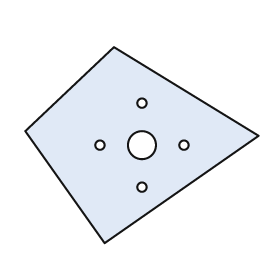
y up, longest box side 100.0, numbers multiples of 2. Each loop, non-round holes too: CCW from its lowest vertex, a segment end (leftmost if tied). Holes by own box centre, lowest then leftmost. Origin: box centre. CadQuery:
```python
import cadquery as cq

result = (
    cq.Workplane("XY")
    .moveTo(-16.0, -42.0)
    .lineTo(50.0, 4.0)
    .lineTo(-12.0, 42.0)
    .lineTo(-50.0, 6.0)
    .close()
    .moveTo(0.0, -18.0)
    .circle(2.0)
    .moveTo(-18.0, 0.0)
    .circle(2.0)
    .moveTo(0.0, 0.0)
    .circle(6.0)
    .moveTo(18.0, 0.0)
    .circle(2.0)
    .moveTo(0.0, 18.0)
    .circle(2.0)
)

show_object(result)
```